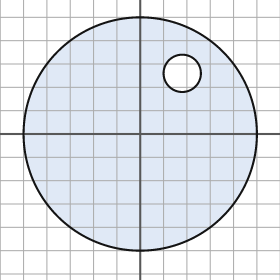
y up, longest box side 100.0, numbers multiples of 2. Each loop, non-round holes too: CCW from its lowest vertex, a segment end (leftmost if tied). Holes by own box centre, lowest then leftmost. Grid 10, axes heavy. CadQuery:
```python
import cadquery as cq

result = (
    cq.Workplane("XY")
    .moveTo(0.0, 0.0)
    .circle(50.0)
    .moveTo(18.0, 26.0)
    .circle(8.0)
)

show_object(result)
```